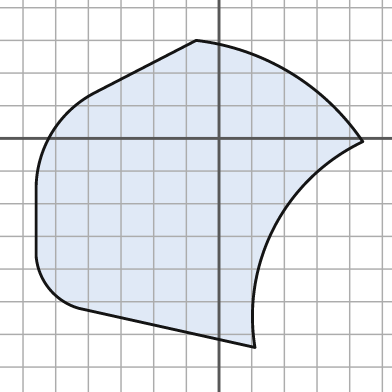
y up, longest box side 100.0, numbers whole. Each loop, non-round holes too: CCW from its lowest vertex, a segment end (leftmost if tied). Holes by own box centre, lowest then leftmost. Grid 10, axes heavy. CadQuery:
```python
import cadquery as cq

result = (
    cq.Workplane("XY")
    .moveTo(11.0, -64.0)
    .threePointArc((17.0, -27.0), (44.0, -1.0))
    .threePointArc((22.0, 20.0), (-7.0, 30.0))
    .lineTo(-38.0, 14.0)
    .threePointArc((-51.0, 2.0), (-56.0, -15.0))
    .lineTo(-56.0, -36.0)
    .threePointArc((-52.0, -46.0), (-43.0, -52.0))
    .close()
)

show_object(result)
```